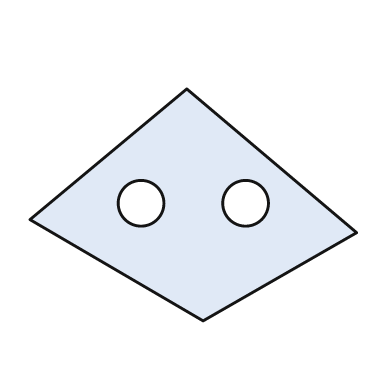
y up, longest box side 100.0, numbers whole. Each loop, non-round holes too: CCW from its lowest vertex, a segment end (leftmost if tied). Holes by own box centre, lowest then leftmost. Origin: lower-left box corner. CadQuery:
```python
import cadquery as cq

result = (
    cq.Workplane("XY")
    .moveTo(53.0, 0.0)
    .lineTo(100.0, 27.0)
    .lineTo(48.0, 71.0)
    .lineTo(0.0, 31.0)
    .close()
    .moveTo(34.0, 36.0)
    .circle(7.0)
    .moveTo(66.0, 36.0)
    .circle(7.0)
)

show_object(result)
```